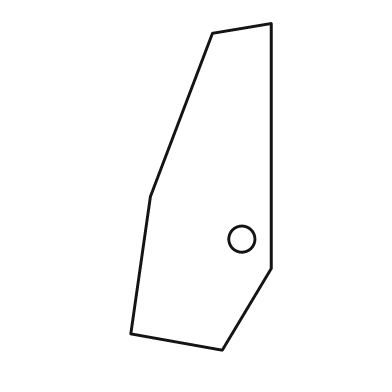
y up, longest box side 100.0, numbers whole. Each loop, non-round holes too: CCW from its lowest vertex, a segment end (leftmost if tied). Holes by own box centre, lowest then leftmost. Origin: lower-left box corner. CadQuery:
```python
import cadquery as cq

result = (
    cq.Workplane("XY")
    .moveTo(28.0, 0.0)
    .lineTo(43.0, 25.0)
    .lineTo(43.0, 100.0)
    .lineTo(25.0, 97.0)
    .lineTo(6.0, 47.0)
    .lineTo(0.0, 5.0)
    .close()
    .moveTo(34.0, 34.0)
    .circle(4.0)
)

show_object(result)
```